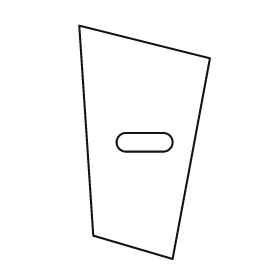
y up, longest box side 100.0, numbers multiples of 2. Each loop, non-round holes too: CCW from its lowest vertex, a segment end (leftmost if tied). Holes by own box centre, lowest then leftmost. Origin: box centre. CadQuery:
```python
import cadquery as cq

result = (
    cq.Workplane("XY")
    .moveTo(12.0, -50.0)
    .lineTo(28.0, 36.0)
    .lineTo(-28.0, 50.0)
    .lineTo(-22.0, -40.0)
    .close()
    .moveTo(-8.0, -4.0)
    .lineTo(8.0, -4.0)
    .threePointArc((12.0, 0.0), (8.0, 4.0))
    .lineTo(-8.0, 4.0)
    .threePointArc((-12.0, 0.0), (-8.0, -4.0))
    .close()
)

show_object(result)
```